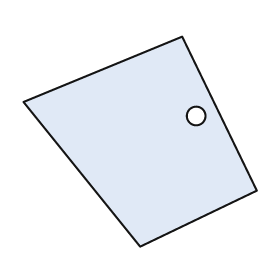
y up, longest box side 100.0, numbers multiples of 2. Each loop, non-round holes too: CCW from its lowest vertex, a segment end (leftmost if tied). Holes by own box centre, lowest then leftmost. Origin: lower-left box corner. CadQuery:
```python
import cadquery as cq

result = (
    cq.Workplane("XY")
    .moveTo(50.0, 0.0)
    .lineTo(100.0, 24.0)
    .lineTo(68.0, 90.0)
    .lineTo(0.0, 62.0)
    .close()
    .moveTo(74.0, 56.0)
    .circle(4.0)
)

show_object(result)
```